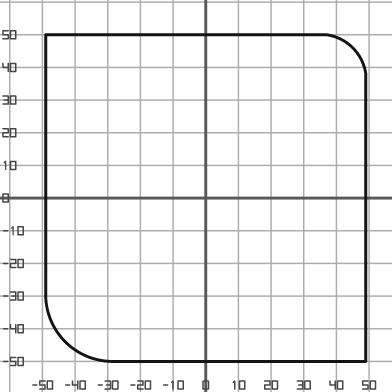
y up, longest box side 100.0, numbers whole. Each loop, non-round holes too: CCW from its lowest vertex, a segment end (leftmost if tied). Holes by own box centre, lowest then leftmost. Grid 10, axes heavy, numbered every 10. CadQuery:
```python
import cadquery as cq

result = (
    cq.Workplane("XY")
    .moveTo(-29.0, -50.0)
    .lineTo(49.0, -50.0)
    .lineTo(49.0, 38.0)
    .threePointArc((45.0, 46.0), (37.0, 50.0))
    .lineTo(-49.0, 50.0)
    .lineTo(-49.0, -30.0)
    .threePointArc((-43.0, -44.0), (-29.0, -50.0))
    .close()
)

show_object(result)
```